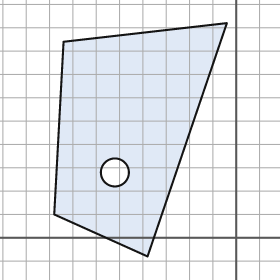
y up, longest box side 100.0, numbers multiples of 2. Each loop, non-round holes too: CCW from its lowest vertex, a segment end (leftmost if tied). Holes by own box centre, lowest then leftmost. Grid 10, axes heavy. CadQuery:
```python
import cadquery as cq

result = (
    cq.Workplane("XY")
    .moveTo(-38.0, -8.0)
    .lineTo(-4.0, 92.0)
    .lineTo(-74.0, 84.0)
    .lineTo(-78.0, 10.0)
    .close()
    .moveTo(-52.0, 28.0)
    .circle(6.0)
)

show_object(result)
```